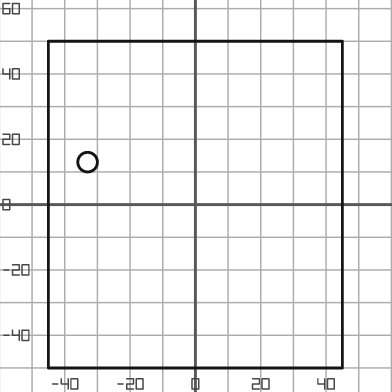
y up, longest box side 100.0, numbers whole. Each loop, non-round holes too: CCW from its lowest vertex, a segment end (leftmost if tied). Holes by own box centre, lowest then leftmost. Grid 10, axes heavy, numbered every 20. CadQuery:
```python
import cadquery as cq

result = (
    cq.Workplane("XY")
    .moveTo(-45.0, -50.0)
    .lineTo(45.0, -50.0)
    .lineTo(45.0, 50.0)
    .lineTo(-45.0, 50.0)
    .close()
    .moveTo(-33.0, 13.0)
    .circle(3.0)
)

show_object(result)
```